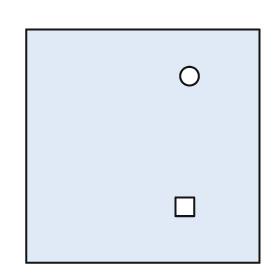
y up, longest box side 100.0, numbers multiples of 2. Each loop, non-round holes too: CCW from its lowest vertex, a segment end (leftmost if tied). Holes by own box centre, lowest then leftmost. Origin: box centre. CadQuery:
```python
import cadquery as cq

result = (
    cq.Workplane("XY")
    .moveTo(-50.0, -50.0)
    .lineTo(50.0, -50.0)
    .lineTo(50.0, 50.0)
    .lineTo(-50.0, 50.0)
    .close()
    .moveTo(14.0, -30.0)
    .lineTo(22.0, -30.0)
    .lineTo(22.0, -22.0)
    .lineTo(14.0, -22.0)
    .close()
    .moveTo(20.0, 30.0)
    .circle(4.0)
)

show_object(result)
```